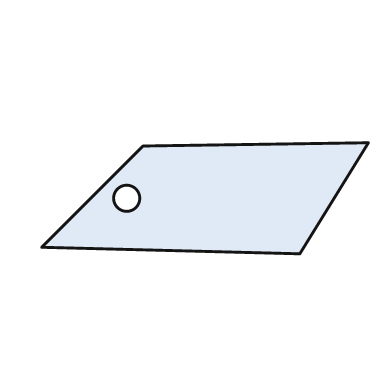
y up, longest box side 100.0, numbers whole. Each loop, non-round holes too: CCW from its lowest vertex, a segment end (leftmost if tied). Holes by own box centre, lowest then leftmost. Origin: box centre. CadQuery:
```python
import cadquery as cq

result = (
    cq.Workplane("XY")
    .moveTo(29.0, -17.0)
    .lineTo(50.0, 17.0)
    .lineTo(-19.0, 16.0)
    .lineTo(-50.0, -15.0)
    .close()
    .moveTo(-24.0, 0.0)
    .circle(4.0)
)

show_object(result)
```